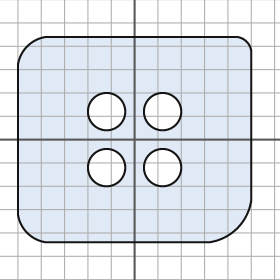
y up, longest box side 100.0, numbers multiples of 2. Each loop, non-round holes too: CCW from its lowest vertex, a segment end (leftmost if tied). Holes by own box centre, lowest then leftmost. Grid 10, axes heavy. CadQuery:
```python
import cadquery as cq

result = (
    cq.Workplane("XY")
    .moveTo(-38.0, -44.0)
    .lineTo(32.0, -44.0)
    .threePointArc((44.0, -38.0), (50.0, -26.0))
    .lineTo(50.0, 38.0)
    .threePointArc((48.0, 42.0), (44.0, 44.0))
    .lineTo(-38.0, 44.0)
    .threePointArc((-46.0, 40.0), (-50.0, 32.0))
    .lineTo(-50.0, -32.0)
    .threePointArc((-46.0, -40.0), (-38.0, -44.0))
    .close()
    .moveTo(-12.0, -12.0)
    .circle(8.0)
    .moveTo(12.0, -12.0)
    .circle(8.0)
    .moveTo(-12.0, 12.0)
    .circle(8.0)
    .moveTo(12.0, 12.0)
    .circle(8.0)
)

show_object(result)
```